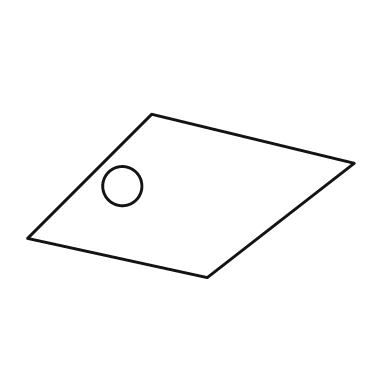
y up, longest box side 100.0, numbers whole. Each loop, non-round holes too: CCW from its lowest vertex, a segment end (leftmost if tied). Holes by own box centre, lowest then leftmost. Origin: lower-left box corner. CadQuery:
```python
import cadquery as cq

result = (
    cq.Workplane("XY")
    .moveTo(55.0, 0.0)
    .lineTo(100.0, 35.0)
    .lineTo(38.0, 50.0)
    .lineTo(0.0, 12.0)
    .close()
    .moveTo(29.0, 28.0)
    .circle(6.0)
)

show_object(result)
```